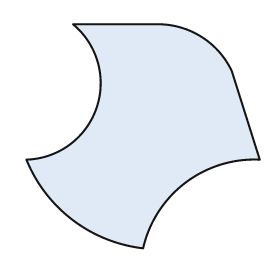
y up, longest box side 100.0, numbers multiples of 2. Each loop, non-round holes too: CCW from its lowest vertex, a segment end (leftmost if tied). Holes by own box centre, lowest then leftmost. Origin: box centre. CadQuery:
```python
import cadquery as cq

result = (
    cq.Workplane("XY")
    .moveTo(0.0, -48.0)
    .threePointArc((18.0, -20.0), (50.0, -10.0))
    .lineTo(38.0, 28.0)
    .threePointArc((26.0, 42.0), (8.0, 48.0))
    .lineTo(-30.0, 48.0)
    .threePointArc((-20.0, 12.0), (-50.0, -10.0))
    .threePointArc((-30.0, -36.0), (0.0, -48.0))
    .close()
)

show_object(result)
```